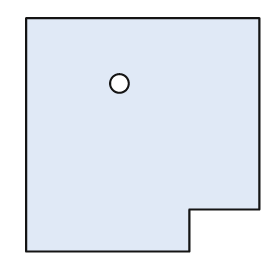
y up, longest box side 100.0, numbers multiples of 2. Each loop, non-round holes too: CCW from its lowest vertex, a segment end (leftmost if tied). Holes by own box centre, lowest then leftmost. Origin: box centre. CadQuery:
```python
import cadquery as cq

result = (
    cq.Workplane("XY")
    .moveTo(-50.0, -50.0)
    .lineTo(20.0, -50.0)
    .lineTo(20.0, -32.0)
    .lineTo(50.0, -32.0)
    .lineTo(50.0, 50.0)
    .lineTo(-50.0, 50.0)
    .close()
    .moveTo(-10.0, 22.0)
    .circle(4.0)
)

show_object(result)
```